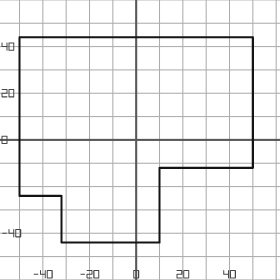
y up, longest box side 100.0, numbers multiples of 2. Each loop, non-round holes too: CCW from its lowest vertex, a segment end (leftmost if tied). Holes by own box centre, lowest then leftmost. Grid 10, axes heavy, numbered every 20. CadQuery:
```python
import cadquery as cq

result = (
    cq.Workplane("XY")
    .moveTo(-32.0, -44.0)
    .lineTo(10.0, -44.0)
    .lineTo(10.0, -12.0)
    .lineTo(50.0, -12.0)
    .lineTo(50.0, 44.0)
    .lineTo(-50.0, 44.0)
    .lineTo(-50.0, -24.0)
    .lineTo(-32.0, -24.0)
    .close()
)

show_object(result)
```